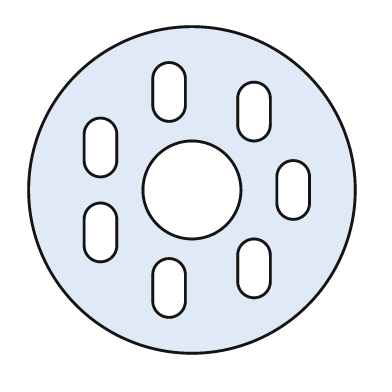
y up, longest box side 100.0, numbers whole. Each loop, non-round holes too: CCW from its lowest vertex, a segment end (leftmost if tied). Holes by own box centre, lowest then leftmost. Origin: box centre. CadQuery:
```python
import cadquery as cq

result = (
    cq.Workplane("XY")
    .moveTo(0.0, 0.0)
    .circle(50.0)
    .moveTo(-12.0, -34.0)
    .threePointArc((-7.0, -39.0), (-2.0, -34.0))
    .lineTo(-2.0, -26.0)
    .threePointArc((-7.0, -21.0), (-12.0, -26.0))
    .close()
    .moveTo(14.0, -28.0)
    .threePointArc((19.0, -33.0), (24.0, -28.0))
    .lineTo(24.0, -20.0)
    .threePointArc((19.0, -15.0), (14.0, -20.0))
    .close()
    .moveTo(-33.0, -17.0)
    .threePointArc((-28.0, -22.0), (-23.0, -17.0))
    .lineTo(-23.0, -9.0)
    .threePointArc((-28.0, -4.0), (-33.0, -9.0))
    .close()
    .moveTo(0.0, 0.0)
    .circle(15.0)
    .moveTo(26.0, -4.0)
    .threePointArc((31.0, -9.0), (36.0, -4.0))
    .lineTo(36.0, 4.0)
    .threePointArc((31.0, 9.0), (26.0, 4.0))
    .close()
    .moveTo(-33.0, 9.0)
    .threePointArc((-28.0, 4.0), (-23.0, 9.0))
    .lineTo(-23.0, 17.0)
    .threePointArc((-28.0, 22.0), (-33.0, 17.0))
    .close()
    .moveTo(14.0, 20.0)
    .threePointArc((19.0, 15.0), (24.0, 20.0))
    .lineTo(24.0, 28.0)
    .threePointArc((19.0, 33.0), (14.0, 28.0))
    .close()
    .moveTo(-12.0, 26.0)
    .threePointArc((-7.0, 21.0), (-2.0, 26.0))
    .lineTo(-2.0, 34.0)
    .threePointArc((-7.0, 39.0), (-12.0, 34.0))
    .close()
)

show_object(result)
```